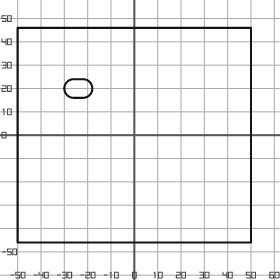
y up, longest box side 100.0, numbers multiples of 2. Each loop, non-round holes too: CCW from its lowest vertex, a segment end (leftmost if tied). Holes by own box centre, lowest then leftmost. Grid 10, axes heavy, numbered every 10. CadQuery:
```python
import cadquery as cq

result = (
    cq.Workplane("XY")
    .moveTo(-50.0, -46.0)
    .lineTo(50.0, -46.0)
    .lineTo(50.0, 46.0)
    .lineTo(-50.0, 46.0)
    .close()
    .moveTo(-26.0, 16.0)
    .lineTo(-22.0, 16.0)
    .threePointArc((-18.0, 20.0), (-22.0, 24.0))
    .lineTo(-26.0, 24.0)
    .threePointArc((-30.0, 20.0), (-26.0, 16.0))
    .close()
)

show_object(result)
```